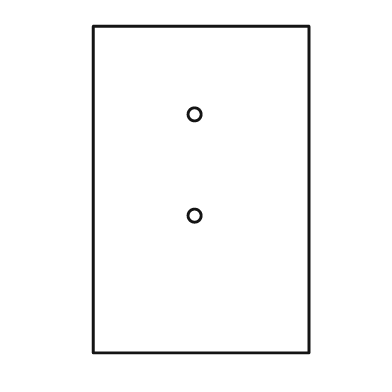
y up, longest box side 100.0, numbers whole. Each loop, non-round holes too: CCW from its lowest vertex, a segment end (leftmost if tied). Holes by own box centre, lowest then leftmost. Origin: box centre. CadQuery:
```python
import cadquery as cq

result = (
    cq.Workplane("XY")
    .moveTo(-33.0, -50.0)
    .lineTo(33.0, -50.0)
    .lineTo(33.0, 50.0)
    .lineTo(-33.0, 50.0)
    .close()
    .moveTo(-2.0, -8.0)
    .circle(2.0)
    .moveTo(-2.0, 23.0)
    .circle(2.0)
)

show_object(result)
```